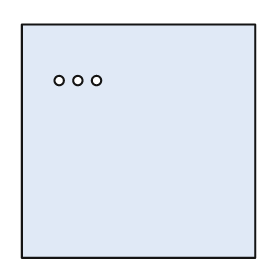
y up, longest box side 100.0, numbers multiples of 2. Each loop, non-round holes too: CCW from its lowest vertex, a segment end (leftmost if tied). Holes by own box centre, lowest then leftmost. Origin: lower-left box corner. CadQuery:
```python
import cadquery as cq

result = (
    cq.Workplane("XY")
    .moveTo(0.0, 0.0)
    .lineTo(100.0, 0.0)
    .lineTo(100.0, 100.0)
    .lineTo(0.0, 100.0)
    .close()
    .moveTo(16.0, 76.0)
    .circle(2.0)
    .moveTo(24.0, 76.0)
    .circle(2.0)
    .moveTo(32.0, 76.0)
    .circle(2.0)
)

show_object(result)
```